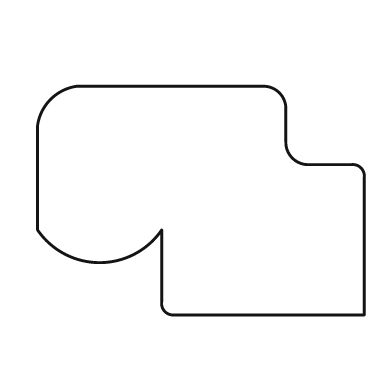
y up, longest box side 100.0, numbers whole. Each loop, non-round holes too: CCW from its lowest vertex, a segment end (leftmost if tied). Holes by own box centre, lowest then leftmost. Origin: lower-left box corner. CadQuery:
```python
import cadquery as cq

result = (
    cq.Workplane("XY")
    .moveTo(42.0, 0.0)
    .lineTo(100.0, 0.0)
    .lineTo(100.0, 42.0)
    .threePointArc((99.0, 45.0), (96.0, 46.0))
    .lineTo(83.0, 46.0)
    .threePointArc((78.0, 48.0), (76.0, 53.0))
    .lineTo(76.0, 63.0)
    .threePointArc((74.0, 68.0), (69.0, 70.0))
    .lineTo(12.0, 70.0)
    .threePointArc((4.0, 66.0), (0.0, 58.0))
    .lineTo(0.0, 26.0)
    .threePointArc((19.0, 16.0), (38.0, 26.0))
    .lineTo(38.0, 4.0)
    .threePointArc((39.0, 1.0), (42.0, 0.0))
    .close()
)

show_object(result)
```